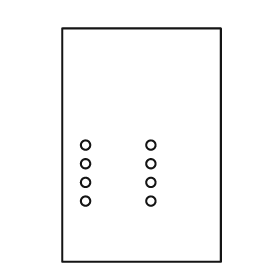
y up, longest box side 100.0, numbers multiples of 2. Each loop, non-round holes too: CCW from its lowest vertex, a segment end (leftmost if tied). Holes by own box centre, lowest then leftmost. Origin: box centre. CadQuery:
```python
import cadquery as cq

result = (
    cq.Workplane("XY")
    .moveTo(-34.0, -50.0)
    .lineTo(34.0, -50.0)
    .lineTo(34.0, 50.0)
    .lineTo(-34.0, 50.0)
    .close()
    .moveTo(-24.0, -24.0)
    .circle(2.0)
    .moveTo(4.0, -24.0)
    .circle(2.0)
    .moveTo(-24.0, -16.0)
    .circle(2.0)
    .moveTo(4.0, -16.0)
    .circle(2.0)
    .moveTo(-24.0, -8.0)
    .circle(2.0)
    .moveTo(4.0, -8.0)
    .circle(2.0)
    .moveTo(-24.0, 0.0)
    .circle(2.0)
    .moveTo(4.0, 0.0)
    .circle(2.0)
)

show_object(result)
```